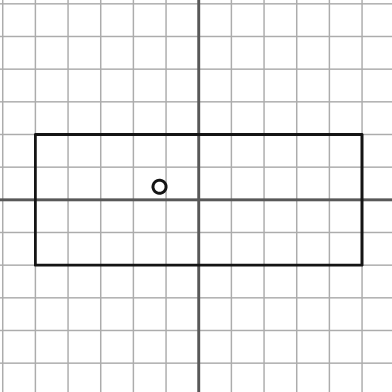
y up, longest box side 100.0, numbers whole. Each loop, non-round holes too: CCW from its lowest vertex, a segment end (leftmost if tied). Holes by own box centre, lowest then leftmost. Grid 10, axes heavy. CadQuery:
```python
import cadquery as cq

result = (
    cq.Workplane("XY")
    .moveTo(-50.0, -20.0)
    .lineTo(50.0, -20.0)
    .lineTo(50.0, 20.0)
    .lineTo(-50.0, 20.0)
    .close()
    .moveTo(-12.0, 4.0)
    .circle(2.0)
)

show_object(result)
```